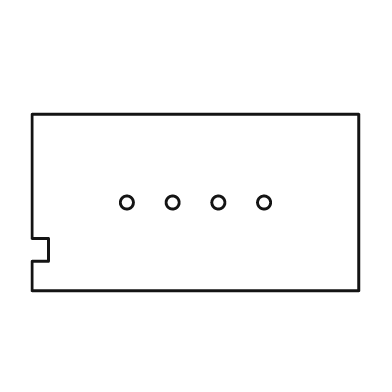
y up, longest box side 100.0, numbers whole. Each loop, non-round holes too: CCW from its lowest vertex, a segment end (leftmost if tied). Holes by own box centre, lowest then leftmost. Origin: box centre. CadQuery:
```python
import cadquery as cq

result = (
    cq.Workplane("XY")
    .moveTo(-50.0, -27.0)
    .lineTo(50.0, -27.0)
    .lineTo(50.0, 27.0)
    .lineTo(-50.0, 27.0)
    .lineTo(-50.0, -11.0)
    .lineTo(-45.0, -11.0)
    .lineTo(-45.0, -18.0)
    .lineTo(-50.0, -18.0)
    .close()
    .moveTo(-21.0, 0.0)
    .circle(2.0)
    .moveTo(-7.0, 0.0)
    .circle(2.0)
    .moveTo(7.0, 0.0)
    .circle(2.0)
    .moveTo(21.0, 0.0)
    .circle(2.0)
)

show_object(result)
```